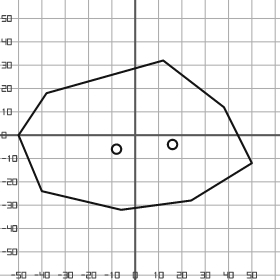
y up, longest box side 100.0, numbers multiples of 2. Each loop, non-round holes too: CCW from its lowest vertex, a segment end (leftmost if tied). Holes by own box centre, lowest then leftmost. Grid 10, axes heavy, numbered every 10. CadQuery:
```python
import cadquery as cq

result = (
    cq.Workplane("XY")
    .moveTo(-6.0, -32.0)
    .lineTo(24.0, -28.0)
    .lineTo(50.0, -12.0)
    .lineTo(38.0, 12.0)
    .lineTo(12.0, 32.0)
    .lineTo(-38.0, 18.0)
    .lineTo(-50.0, 0.0)
    .lineTo(-40.0, -24.0)
    .close()
    .moveTo(-8.0, -6.0)
    .circle(2.0)
    .moveTo(16.0, -4.0)
    .circle(2.0)
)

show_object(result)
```